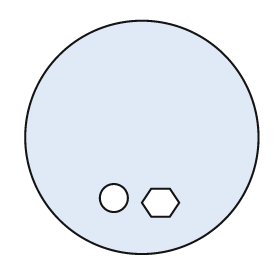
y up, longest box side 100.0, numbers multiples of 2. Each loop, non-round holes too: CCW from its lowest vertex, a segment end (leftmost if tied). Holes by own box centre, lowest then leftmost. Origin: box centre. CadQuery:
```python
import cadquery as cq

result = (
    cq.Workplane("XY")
    .moveTo(0.0, 0.0)
    .circle(50.0)
    .moveTo(4.0, -34.0)
    .lineTo(12.0, -34.0)
    .lineTo(16.0, -28.0)
    .lineTo(12.0, -22.0)
    .lineTo(4.0, -22.0)
    .lineTo(0.0, -28.0)
    .close()
    .moveTo(-12.0, -26.0)
    .circle(6.0)
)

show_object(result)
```